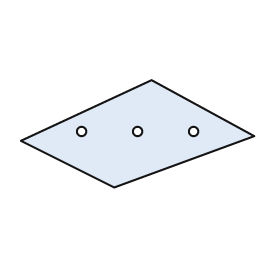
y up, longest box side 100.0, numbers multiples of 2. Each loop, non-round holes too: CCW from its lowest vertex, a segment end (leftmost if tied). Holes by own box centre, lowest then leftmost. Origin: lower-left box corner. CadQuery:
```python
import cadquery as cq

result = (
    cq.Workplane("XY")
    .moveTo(40.0, 0.0)
    .lineTo(100.0, 22.0)
    .lineTo(56.0, 46.0)
    .lineTo(0.0, 20.0)
    .close()
    .moveTo(26.0, 24.0)
    .circle(2.0)
    .moveTo(50.0, 24.0)
    .circle(2.0)
    .moveTo(74.0, 24.0)
    .circle(2.0)
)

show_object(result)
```